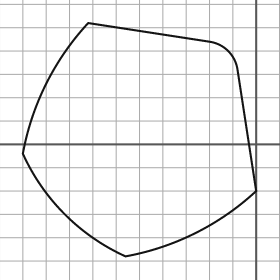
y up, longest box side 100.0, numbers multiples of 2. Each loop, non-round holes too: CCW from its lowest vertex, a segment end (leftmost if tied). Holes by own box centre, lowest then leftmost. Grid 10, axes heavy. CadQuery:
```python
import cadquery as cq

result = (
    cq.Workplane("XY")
    .moveTo(-56.0, -48.0)
    .threePointArc((-26.0, -38.0), (0.0, -20.0))
    .lineTo(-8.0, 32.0)
    .threePointArc((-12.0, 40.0), (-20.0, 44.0))
    .lineTo(-72.0, 52.0)
    .threePointArc((-90.0, 26.0), (-100.0, -4.0))
    .threePointArc((-82.0, -30.0), (-56.0, -48.0))
    .close()
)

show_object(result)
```